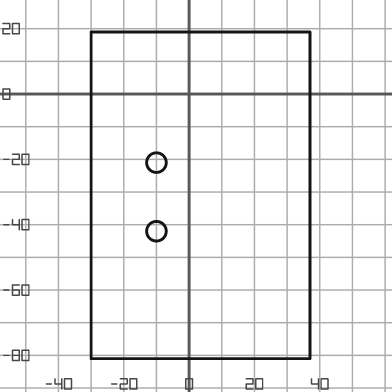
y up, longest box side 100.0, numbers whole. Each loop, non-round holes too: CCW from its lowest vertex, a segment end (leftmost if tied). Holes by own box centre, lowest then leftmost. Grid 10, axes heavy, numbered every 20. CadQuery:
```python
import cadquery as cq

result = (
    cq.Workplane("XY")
    .moveTo(-30.0, -81.0)
    .lineTo(37.0, -81.0)
    .lineTo(37.0, 19.0)
    .lineTo(-30.0, 19.0)
    .close()
    .moveTo(-10.0, -42.0)
    .circle(3.0)
    .moveTo(-10.0, -21.0)
    .circle(3.0)
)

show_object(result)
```